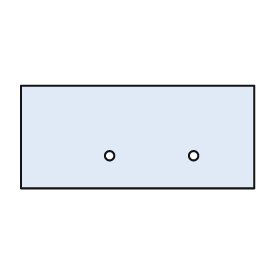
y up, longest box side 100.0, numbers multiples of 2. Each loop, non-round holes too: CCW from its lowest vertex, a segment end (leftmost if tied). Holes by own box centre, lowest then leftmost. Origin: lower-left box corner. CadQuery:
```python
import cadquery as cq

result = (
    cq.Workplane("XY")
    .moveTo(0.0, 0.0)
    .lineTo(100.0, 0.0)
    .lineTo(100.0, 44.0)
    .lineTo(0.0, 44.0)
    .close()
    .moveTo(38.0, 14.0)
    .circle(2.0)
    .moveTo(74.0, 14.0)
    .circle(2.0)
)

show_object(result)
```